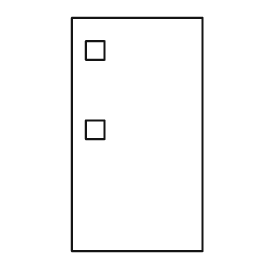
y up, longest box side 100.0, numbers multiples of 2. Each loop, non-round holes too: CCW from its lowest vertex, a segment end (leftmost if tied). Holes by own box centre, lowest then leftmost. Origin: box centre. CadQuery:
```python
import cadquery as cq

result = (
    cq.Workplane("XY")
    .moveTo(-28.0, -50.0)
    .lineTo(28.0, -50.0)
    .lineTo(28.0, 50.0)
    .lineTo(-28.0, 50.0)
    .close()
    .moveTo(-22.0, -2.0)
    .lineTo(-14.0, -2.0)
    .lineTo(-14.0, 6.0)
    .lineTo(-22.0, 6.0)
    .close()
    .moveTo(-22.0, 32.0)
    .lineTo(-14.0, 32.0)
    .lineTo(-14.0, 40.0)
    .lineTo(-22.0, 40.0)
    .close()
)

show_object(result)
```